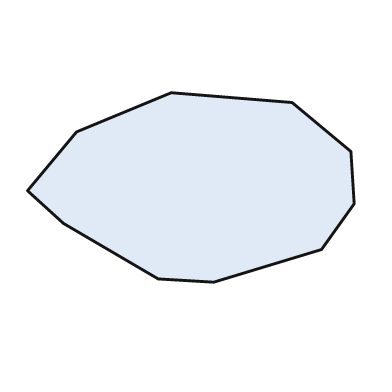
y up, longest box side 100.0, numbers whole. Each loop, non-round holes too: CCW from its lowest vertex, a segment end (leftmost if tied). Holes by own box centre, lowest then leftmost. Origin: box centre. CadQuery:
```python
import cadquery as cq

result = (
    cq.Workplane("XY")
    .moveTo(7.0, -29.0)
    .lineTo(40.0, -19.0)
    .lineTo(50.0, -5.0)
    .lineTo(49.0, 11.0)
    .lineTo(31.0, 26.0)
    .lineTo(-6.0, 29.0)
    .lineTo(-35.0, 17.0)
    .lineTo(-50.0, -1.0)
    .lineTo(-39.0, -11.0)
    .lineTo(-10.0, -28.0)
    .close()
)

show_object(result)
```